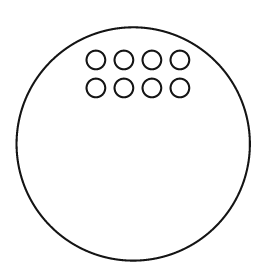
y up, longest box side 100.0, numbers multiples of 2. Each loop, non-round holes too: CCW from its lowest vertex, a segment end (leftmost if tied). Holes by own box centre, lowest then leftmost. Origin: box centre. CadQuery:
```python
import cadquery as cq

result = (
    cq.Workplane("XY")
    .moveTo(0.0, 0.0)
    .circle(50.0)
    .moveTo(-16.0, 24.0)
    .circle(4.0)
    .moveTo(-4.0, 24.0)
    .circle(4.0)
    .moveTo(8.0, 24.0)
    .circle(4.0)
    .moveTo(20.0, 24.0)
    .circle(4.0)
    .moveTo(-16.0, 36.0)
    .circle(4.0)
    .moveTo(-4.0, 36.0)
    .circle(4.0)
    .moveTo(8.0, 36.0)
    .circle(4.0)
    .moveTo(20.0, 36.0)
    .circle(4.0)
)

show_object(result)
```